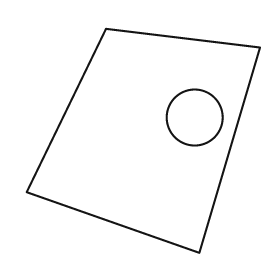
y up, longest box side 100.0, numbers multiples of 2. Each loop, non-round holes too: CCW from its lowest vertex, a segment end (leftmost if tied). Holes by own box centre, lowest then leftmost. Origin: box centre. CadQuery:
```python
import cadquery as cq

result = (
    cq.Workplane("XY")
    .moveTo(24.0, -48.0)
    .lineTo(50.0, 40.0)
    .lineTo(-16.0, 48.0)
    .lineTo(-50.0, -22.0)
    .close()
    .moveTo(22.0, 10.0)
    .circle(12.0)
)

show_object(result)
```